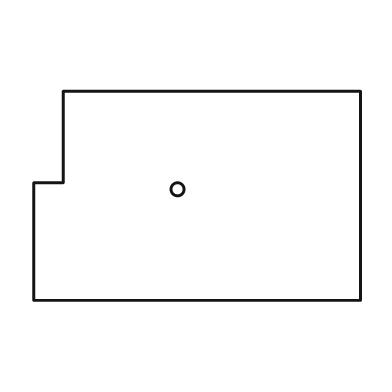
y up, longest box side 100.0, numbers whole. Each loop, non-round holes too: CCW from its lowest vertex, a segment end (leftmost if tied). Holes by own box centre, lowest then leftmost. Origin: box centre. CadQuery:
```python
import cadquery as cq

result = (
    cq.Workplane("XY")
    .moveTo(-50.0, -32.0)
    .lineTo(50.0, -32.0)
    .lineTo(50.0, 32.0)
    .lineTo(-41.0, 32.0)
    .lineTo(-41.0, 4.0)
    .lineTo(-50.0, 4.0)
    .close()
    .moveTo(-6.0, 2.0)
    .circle(2.0)
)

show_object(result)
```